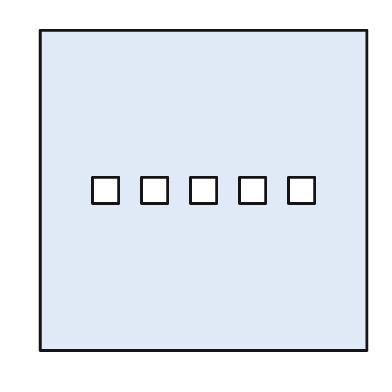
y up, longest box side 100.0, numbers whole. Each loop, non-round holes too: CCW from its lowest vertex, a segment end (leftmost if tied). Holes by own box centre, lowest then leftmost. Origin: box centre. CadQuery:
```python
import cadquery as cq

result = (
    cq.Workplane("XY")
    .moveTo(-50.0, -49.0)
    .lineTo(50.0, -49.0)
    .lineTo(50.0, 49.0)
    .lineTo(-50.0, 49.0)
    .close()
    .moveTo(-34.0, -4.0)
    .lineTo(-26.0, -4.0)
    .lineTo(-26.0, 4.0)
    .lineTo(-34.0, 4.0)
    .close()
    .moveTo(-19.0, -4.0)
    .lineTo(-11.0, -4.0)
    .lineTo(-11.0, 4.0)
    .lineTo(-19.0, 4.0)
    .close()
    .moveTo(-4.0, -4.0)
    .lineTo(4.0, -4.0)
    .lineTo(4.0, 4.0)
    .lineTo(-4.0, 4.0)
    .close()
    .moveTo(11.0, -4.0)
    .lineTo(19.0, -4.0)
    .lineTo(19.0, 4.0)
    .lineTo(11.0, 4.0)
    .close()
    .moveTo(26.0, -4.0)
    .lineTo(34.0, -4.0)
    .lineTo(34.0, 4.0)
    .lineTo(26.0, 4.0)
    .close()
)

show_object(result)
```